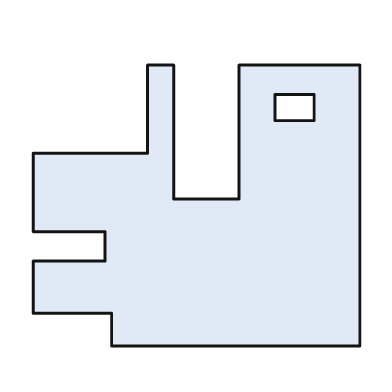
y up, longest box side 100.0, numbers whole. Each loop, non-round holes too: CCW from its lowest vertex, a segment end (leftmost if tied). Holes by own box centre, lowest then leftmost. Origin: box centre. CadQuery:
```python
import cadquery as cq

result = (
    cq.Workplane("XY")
    .moveTo(-26.0, -43.0)
    .lineTo(50.0, -43.0)
    .lineTo(50.0, 43.0)
    .lineTo(13.0, 43.0)
    .lineTo(13.0, 2.0)
    .lineTo(-7.0, 2.0)
    .lineTo(-7.0, 43.0)
    .lineTo(-15.0, 43.0)
    .lineTo(-15.0, 16.0)
    .lineTo(-50.0, 16.0)
    .lineTo(-50.0, -8.0)
    .lineTo(-28.0, -8.0)
    .lineTo(-28.0, -17.0)
    .lineTo(-50.0, -17.0)
    .lineTo(-50.0, -33.0)
    .lineTo(-26.0, -33.0)
    .close()
    .moveTo(24.0, 26.0)
    .lineTo(36.0, 26.0)
    .lineTo(36.0, 34.0)
    .lineTo(24.0, 34.0)
    .close()
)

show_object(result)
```